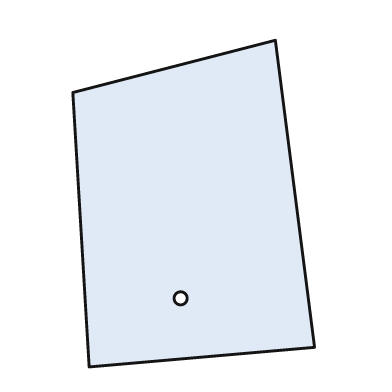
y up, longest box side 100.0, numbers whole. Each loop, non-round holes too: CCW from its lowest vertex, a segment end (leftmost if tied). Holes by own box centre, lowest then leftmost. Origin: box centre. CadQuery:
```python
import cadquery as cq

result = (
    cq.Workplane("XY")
    .moveTo(-32.0, -50.0)
    .lineTo(37.0, -44.0)
    .lineTo(25.0, 50.0)
    .lineTo(-37.0, 34.0)
    .close()
    .moveTo(-4.0, -29.0)
    .circle(2.0)
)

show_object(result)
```